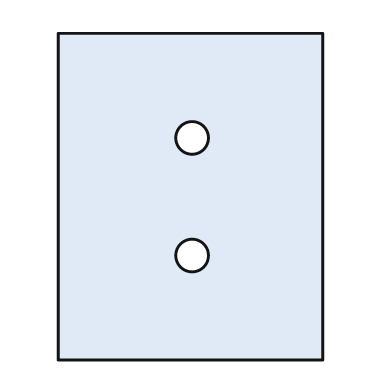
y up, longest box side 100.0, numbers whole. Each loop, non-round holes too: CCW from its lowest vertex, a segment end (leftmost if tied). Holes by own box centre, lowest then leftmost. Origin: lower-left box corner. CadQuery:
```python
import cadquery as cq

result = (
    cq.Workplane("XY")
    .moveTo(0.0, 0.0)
    .lineTo(81.0, 0.0)
    .lineTo(81.0, 100.0)
    .lineTo(0.0, 100.0)
    .close()
    .moveTo(41.0, 32.0)
    .circle(5.0)
    .moveTo(41.0, 68.0)
    .circle(5.0)
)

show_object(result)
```